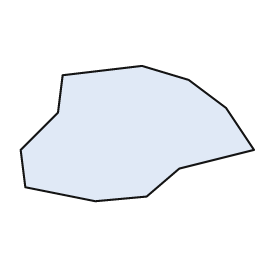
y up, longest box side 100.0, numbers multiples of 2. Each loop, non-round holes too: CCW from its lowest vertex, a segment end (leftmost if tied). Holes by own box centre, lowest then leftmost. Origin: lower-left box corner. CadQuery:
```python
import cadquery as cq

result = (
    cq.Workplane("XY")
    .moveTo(32.0, 0.0)
    .lineTo(54.0, 2.0)
    .lineTo(68.0, 14.0)
    .lineTo(100.0, 22.0)
    .lineTo(88.0, 40.0)
    .lineTo(72.0, 52.0)
    .lineTo(52.0, 58.0)
    .lineTo(18.0, 54.0)
    .lineTo(16.0, 38.0)
    .lineTo(0.0, 22.0)
    .lineTo(2.0, 6.0)
    .close()
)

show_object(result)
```